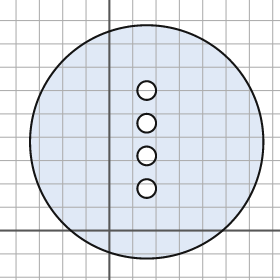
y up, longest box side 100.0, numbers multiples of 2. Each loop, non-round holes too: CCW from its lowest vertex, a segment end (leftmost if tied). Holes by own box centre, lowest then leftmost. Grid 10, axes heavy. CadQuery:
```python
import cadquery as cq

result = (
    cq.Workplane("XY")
    .moveTo(16.0, 38.0)
    .circle(50.0)
    .moveTo(16.0, 18.0)
    .circle(4.0)
    .moveTo(16.0, 32.0)
    .circle(4.0)
    .moveTo(16.0, 46.0)
    .circle(4.0)
    .moveTo(16.0, 60.0)
    .circle(4.0)
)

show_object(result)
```